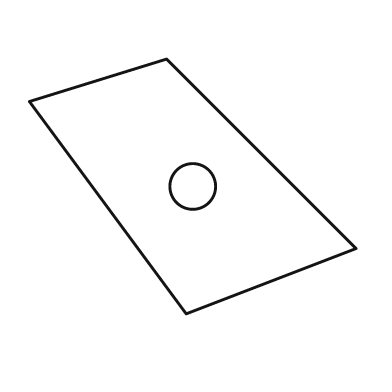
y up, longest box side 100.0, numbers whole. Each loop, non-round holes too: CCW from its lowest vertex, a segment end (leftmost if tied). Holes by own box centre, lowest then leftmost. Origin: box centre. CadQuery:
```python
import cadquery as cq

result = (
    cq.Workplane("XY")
    .moveTo(-2.0, -39.0)
    .lineTo(50.0, -19.0)
    .lineTo(-8.0, 39.0)
    .lineTo(-50.0, 26.0)
    .close()
    .moveTo(0.0, 0.0)
    .circle(7.0)
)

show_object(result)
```